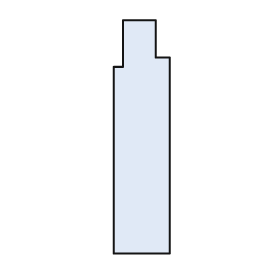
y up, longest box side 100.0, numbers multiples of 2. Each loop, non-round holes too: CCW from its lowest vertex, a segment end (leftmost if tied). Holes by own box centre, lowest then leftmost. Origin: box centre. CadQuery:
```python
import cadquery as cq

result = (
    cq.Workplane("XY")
    .moveTo(-12.0, -50.0)
    .lineTo(12.0, -50.0)
    .lineTo(12.0, 34.0)
    .lineTo(6.0, 34.0)
    .lineTo(6.0, 50.0)
    .lineTo(-8.0, 50.0)
    .lineTo(-8.0, 30.0)
    .lineTo(-12.0, 30.0)
    .close()
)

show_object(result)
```